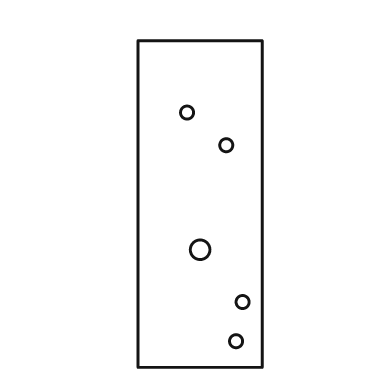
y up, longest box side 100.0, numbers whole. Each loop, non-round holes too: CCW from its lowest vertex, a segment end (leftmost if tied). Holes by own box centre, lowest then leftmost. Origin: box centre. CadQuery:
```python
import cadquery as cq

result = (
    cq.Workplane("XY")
    .moveTo(-19.0, -50.0)
    .lineTo(19.0, -50.0)
    .lineTo(19.0, 50.0)
    .lineTo(-19.0, 50.0)
    .close()
    .moveTo(11.0, -42.0)
    .circle(2.0)
    .moveTo(13.0, -30.0)
    .circle(2.0)
    .moveTo(0.0, -14.0)
    .circle(3.0)
    .moveTo(8.0, 18.0)
    .circle(2.0)
    .moveTo(-4.0, 28.0)
    .circle(2.0)
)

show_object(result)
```